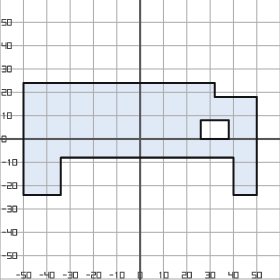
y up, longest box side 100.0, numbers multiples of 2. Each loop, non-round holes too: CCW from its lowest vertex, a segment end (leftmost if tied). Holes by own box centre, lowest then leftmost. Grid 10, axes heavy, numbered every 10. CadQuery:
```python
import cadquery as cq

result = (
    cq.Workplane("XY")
    .moveTo(-50.0, -24.0)
    .lineTo(-34.0, -24.0)
    .lineTo(-34.0, -8.0)
    .lineTo(40.0, -8.0)
    .lineTo(40.0, -24.0)
    .lineTo(50.0, -24.0)
    .lineTo(50.0, 18.0)
    .lineTo(32.0, 18.0)
    .lineTo(32.0, 24.0)
    .lineTo(-50.0, 24.0)
    .close()
    .moveTo(26.0, 0.0)
    .lineTo(38.0, 0.0)
    .lineTo(38.0, 8.0)
    .lineTo(26.0, 8.0)
    .close()
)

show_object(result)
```